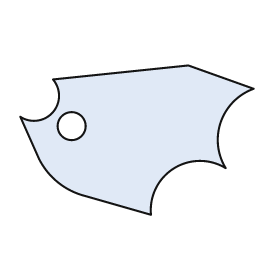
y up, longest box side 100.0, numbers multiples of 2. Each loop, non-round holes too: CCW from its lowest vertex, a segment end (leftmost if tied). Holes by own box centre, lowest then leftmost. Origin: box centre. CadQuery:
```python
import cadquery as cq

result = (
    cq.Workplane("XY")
    .moveTo(6.0, -32.0)
    .threePointArc((16.0, -12.0), (38.0, -12.0))
    .threePointArc((36.0, 8.0), (50.0, 22.0))
    .lineTo(22.0, 32.0)
    .lineTo(-36.0, 26.0)
    .threePointArc((-36.0, 12.0), (-50.0, 10.0))
    .lineTo(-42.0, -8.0)
    .threePointArc((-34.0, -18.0), (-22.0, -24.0))
    .close()
    .moveTo(-28.0, 6.0)
    .circle(6.0)
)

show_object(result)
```